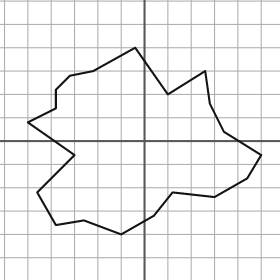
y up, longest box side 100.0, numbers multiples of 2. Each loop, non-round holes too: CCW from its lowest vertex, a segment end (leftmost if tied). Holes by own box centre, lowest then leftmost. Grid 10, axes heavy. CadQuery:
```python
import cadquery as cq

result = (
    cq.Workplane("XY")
    .moveTo(-10.0, -40.0)
    .lineTo(4.0, -32.0)
    .lineTo(12.0, -22.0)
    .lineTo(30.0, -24.0)
    .lineTo(44.0, -16.0)
    .lineTo(50.0, -6.0)
    .lineTo(34.0, 4.0)
    .lineTo(28.0, 16.0)
    .lineTo(26.0, 30.0)
    .lineTo(10.0, 20.0)
    .lineTo(-4.0, 40.0)
    .lineTo(-22.0, 30.0)
    .lineTo(-32.0, 28.0)
    .lineTo(-38.0, 22.0)
    .lineTo(-38.0, 14.0)
    .lineTo(-50.0, 8.0)
    .lineTo(-30.0, -6.0)
    .lineTo(-46.0, -22.0)
    .lineTo(-38.0, -36.0)
    .lineTo(-26.0, -34.0)
    .close()
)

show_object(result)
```